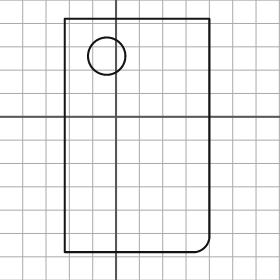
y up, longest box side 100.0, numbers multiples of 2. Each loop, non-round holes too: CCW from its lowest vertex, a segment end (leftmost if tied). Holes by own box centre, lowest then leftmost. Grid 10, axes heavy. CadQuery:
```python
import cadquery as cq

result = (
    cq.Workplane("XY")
    .moveTo(-22.0, -58.0)
    .lineTo(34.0, -58.0)
    .threePointArc((38.0, -56.0), (40.0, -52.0))
    .lineTo(40.0, 42.0)
    .lineTo(-22.0, 42.0)
    .close()
    .moveTo(-4.0, 26.0)
    .circle(8.0)
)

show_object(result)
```